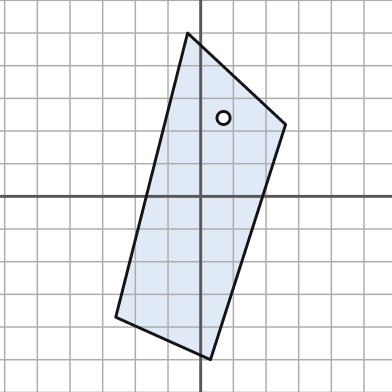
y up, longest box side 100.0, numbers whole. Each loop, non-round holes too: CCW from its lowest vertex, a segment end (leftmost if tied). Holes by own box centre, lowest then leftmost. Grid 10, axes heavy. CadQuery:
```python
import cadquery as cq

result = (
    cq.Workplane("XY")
    .moveTo(3.0, -50.0)
    .lineTo(26.0, 22.0)
    .lineTo(-4.0, 50.0)
    .lineTo(-26.0, -37.0)
    .close()
    .moveTo(7.0, 24.0)
    .circle(2.0)
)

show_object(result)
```